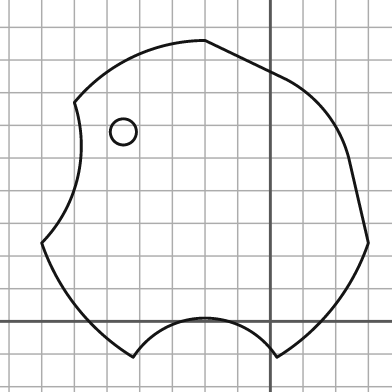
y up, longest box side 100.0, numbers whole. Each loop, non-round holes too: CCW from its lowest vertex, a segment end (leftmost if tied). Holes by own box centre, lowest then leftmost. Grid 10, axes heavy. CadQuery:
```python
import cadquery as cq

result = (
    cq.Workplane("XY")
    .moveTo(-42.0, -11.0)
    .threePointArc((-20.0, 1.0), (2.0, -11.0))
    .threePointArc((19.0, 4.0), (30.0, 24.0))
    .lineTo(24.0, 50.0)
    .threePointArc((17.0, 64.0), (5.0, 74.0))
    .lineTo(-20.0, 86.0)
    .threePointArc((-42.0, 81.0), (-60.0, 67.0))
    .threePointArc((-59.0, 44.0), (-70.0, 24.0))
    .threePointArc((-59.0, 4.0), (-42.0, -11.0))
    .close()
    .moveTo(-45.0, 58.0)
    .circle(4.0)
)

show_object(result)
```